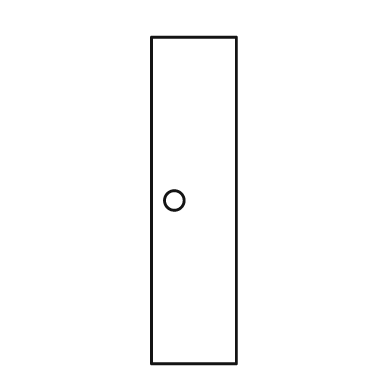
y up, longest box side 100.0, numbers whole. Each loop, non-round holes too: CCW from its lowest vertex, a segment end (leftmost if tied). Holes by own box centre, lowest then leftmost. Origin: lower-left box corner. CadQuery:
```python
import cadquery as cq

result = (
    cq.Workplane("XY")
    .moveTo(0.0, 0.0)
    .lineTo(26.0, 0.0)
    .lineTo(26.0, 100.0)
    .lineTo(0.0, 100.0)
    .close()
    .moveTo(7.0, 50.0)
    .circle(3.0)
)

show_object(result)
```